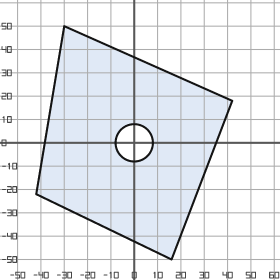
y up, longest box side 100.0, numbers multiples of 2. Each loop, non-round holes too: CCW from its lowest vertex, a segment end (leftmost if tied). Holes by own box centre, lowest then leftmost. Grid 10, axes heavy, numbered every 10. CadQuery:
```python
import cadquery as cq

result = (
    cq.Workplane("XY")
    .moveTo(16.0, -50.0)
    .lineTo(42.0, 18.0)
    .lineTo(-30.0, 50.0)
    .lineTo(-42.0, -22.0)
    .close()
    .moveTo(0.0, 0.0)
    .circle(8.0)
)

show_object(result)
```